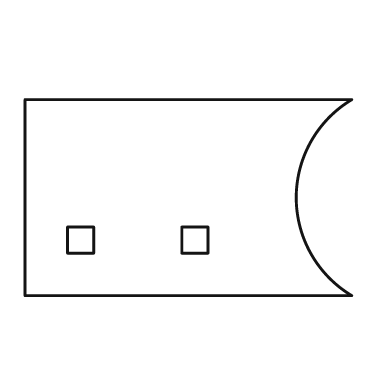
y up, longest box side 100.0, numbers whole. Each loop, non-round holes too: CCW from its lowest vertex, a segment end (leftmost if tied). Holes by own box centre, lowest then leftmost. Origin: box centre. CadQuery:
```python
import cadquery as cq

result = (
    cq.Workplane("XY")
    .moveTo(-50.0, -30.0)
    .lineTo(50.0, -30.0)
    .threePointArc((33.0, 0.0), (50.0, 30.0))
    .lineTo(-50.0, 30.0)
    .close()
    .moveTo(-37.0, -17.0)
    .lineTo(-29.0, -17.0)
    .lineTo(-29.0, -9.0)
    .lineTo(-37.0, -9.0)
    .close()
    .moveTo(-2.0, -17.0)
    .lineTo(6.0, -17.0)
    .lineTo(6.0, -9.0)
    .lineTo(-2.0, -9.0)
    .close()
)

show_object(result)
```